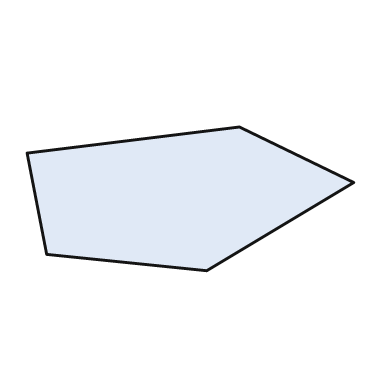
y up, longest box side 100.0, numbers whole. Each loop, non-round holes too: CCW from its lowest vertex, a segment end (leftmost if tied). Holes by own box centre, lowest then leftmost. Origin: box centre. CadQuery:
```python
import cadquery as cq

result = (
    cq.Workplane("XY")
    .moveTo(5.0, -22.0)
    .lineTo(50.0, 5.0)
    .lineTo(15.0, 22.0)
    .lineTo(-50.0, 14.0)
    .lineTo(-44.0, -17.0)
    .close()
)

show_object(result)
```